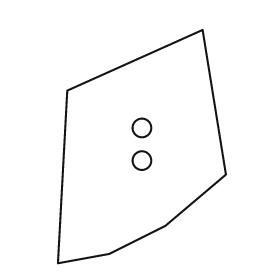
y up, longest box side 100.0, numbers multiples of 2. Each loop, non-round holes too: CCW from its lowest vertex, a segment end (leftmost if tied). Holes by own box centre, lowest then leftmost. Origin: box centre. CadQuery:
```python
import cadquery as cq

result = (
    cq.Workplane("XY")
    .moveTo(-36.0, -50.0)
    .lineTo(-14.0, -46.0)
    .lineTo(10.0, -34.0)
    .lineTo(36.0, -12.0)
    .lineTo(26.0, 50.0)
    .lineTo(-32.0, 24.0)
    .close()
    .moveTo(0.0, -6.0)
    .circle(4.0)
    .moveTo(0.0, 8.0)
    .circle(4.0)
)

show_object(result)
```